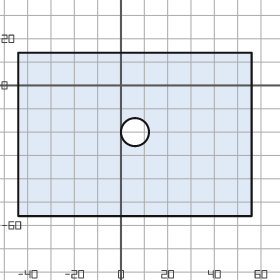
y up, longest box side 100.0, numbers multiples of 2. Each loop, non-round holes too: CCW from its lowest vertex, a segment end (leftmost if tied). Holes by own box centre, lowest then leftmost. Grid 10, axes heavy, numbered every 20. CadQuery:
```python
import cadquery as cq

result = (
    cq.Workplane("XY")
    .moveTo(-44.0, -56.0)
    .lineTo(56.0, -56.0)
    .lineTo(56.0, 14.0)
    .lineTo(-44.0, 14.0)
    .close()
    .moveTo(6.0, -20.0)
    .circle(6.0)
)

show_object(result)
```